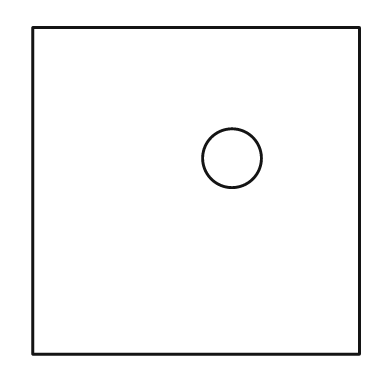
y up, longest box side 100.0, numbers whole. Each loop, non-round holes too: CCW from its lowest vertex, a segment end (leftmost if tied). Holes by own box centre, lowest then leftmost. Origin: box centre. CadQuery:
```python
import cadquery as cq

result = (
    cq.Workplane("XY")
    .moveTo(-50.0, -50.0)
    .lineTo(50.0, -50.0)
    .lineTo(50.0, 50.0)
    .lineTo(-50.0, 50.0)
    .close()
    .moveTo(11.0, 10.0)
    .circle(9.0)
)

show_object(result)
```